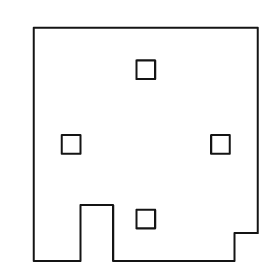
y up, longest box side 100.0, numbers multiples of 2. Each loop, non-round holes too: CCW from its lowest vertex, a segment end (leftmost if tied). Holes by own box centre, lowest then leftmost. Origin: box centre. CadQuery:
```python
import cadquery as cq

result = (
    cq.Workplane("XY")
    .moveTo(-48.0, -50.0)
    .lineTo(-28.0, -50.0)
    .lineTo(-28.0, -26.0)
    .lineTo(-14.0, -26.0)
    .lineTo(-14.0, -50.0)
    .lineTo(38.0, -50.0)
    .lineTo(38.0, -38.0)
    .lineTo(48.0, -38.0)
    .lineTo(48.0, 50.0)
    .lineTo(-48.0, 50.0)
    .close()
    .moveTo(-4.0, -36.0)
    .lineTo(4.0, -36.0)
    .lineTo(4.0, -28.0)
    .lineTo(-4.0, -28.0)
    .close()
    .moveTo(-36.0, -4.0)
    .lineTo(-28.0, -4.0)
    .lineTo(-28.0, 4.0)
    .lineTo(-36.0, 4.0)
    .close()
    .moveTo(28.0, -4.0)
    .lineTo(36.0, -4.0)
    .lineTo(36.0, 4.0)
    .lineTo(28.0, 4.0)
    .close()
    .moveTo(-4.0, 28.0)
    .lineTo(4.0, 28.0)
    .lineTo(4.0, 36.0)
    .lineTo(-4.0, 36.0)
    .close()
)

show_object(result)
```